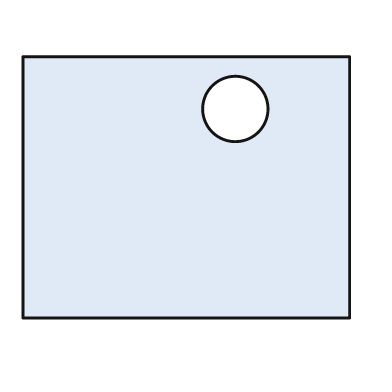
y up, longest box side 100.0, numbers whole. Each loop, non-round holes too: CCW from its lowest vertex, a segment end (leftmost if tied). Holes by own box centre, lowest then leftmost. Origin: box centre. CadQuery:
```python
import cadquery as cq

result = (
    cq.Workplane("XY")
    .moveTo(-50.0, -40.0)
    .lineTo(50.0, -40.0)
    .lineTo(50.0, 40.0)
    .lineTo(-50.0, 40.0)
    .close()
    .moveTo(15.0, 24.0)
    .circle(10.0)
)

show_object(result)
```